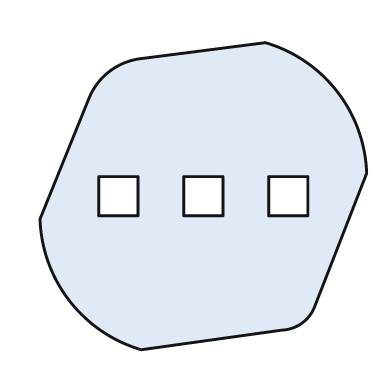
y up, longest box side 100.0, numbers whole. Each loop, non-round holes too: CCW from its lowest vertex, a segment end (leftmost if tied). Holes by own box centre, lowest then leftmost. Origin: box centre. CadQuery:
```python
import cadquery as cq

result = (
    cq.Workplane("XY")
    .moveTo(-19.0, -47.0)
    .lineTo(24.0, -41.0)
    .threePointArc((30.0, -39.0), (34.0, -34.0))
    .lineTo(50.0, 7.0)
    .threePointArc((41.0, 32.0), (19.0, 47.0))
    .lineTo(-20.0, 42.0)
    .threePointArc((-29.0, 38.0), (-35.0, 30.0))
    .lineTo(-50.0, -7.0)
    .threePointArc((-41.0, -32.0), (-19.0, -47.0))
    .close()
    .moveTo(-32.0, -6.0)
    .lineTo(-20.0, -6.0)
    .lineTo(-20.0, 6.0)
    .lineTo(-32.0, 6.0)
    .close()
    .moveTo(-6.0, -6.0)
    .lineTo(6.0, -6.0)
    .lineTo(6.0, 6.0)
    .lineTo(-6.0, 6.0)
    .close()
    .moveTo(20.0, -6.0)
    .lineTo(32.0, -6.0)
    .lineTo(32.0, 6.0)
    .lineTo(20.0, 6.0)
    .close()
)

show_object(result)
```